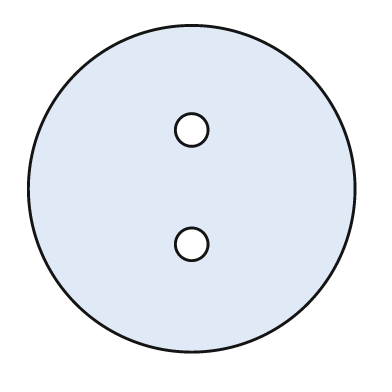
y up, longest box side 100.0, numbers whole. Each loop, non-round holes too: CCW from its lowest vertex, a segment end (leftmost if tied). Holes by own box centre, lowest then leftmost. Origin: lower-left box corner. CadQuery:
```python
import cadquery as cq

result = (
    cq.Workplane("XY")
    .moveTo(50.0, 50.0)
    .circle(50.0)
    .moveTo(50.0, 33.0)
    .circle(5.0)
    .moveTo(50.0, 68.0)
    .circle(5.0)
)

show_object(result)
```